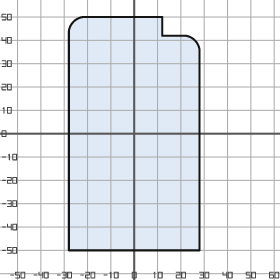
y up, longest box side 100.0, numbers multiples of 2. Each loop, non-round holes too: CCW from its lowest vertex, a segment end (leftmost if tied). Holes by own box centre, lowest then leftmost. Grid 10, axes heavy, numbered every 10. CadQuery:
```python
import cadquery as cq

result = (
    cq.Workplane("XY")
    .moveTo(-28.0, -50.0)
    .lineTo(28.0, -50.0)
    .lineTo(28.0, 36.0)
    .threePointArc((26.0, 40.0), (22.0, 42.0))
    .lineTo(12.0, 42.0)
    .lineTo(12.0, 50.0)
    .lineTo(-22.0, 50.0)
    .threePointArc((-26.0, 48.0), (-28.0, 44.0))
    .close()
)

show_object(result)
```